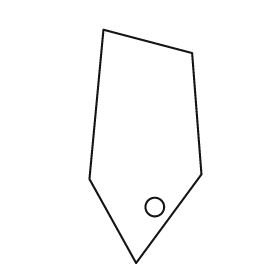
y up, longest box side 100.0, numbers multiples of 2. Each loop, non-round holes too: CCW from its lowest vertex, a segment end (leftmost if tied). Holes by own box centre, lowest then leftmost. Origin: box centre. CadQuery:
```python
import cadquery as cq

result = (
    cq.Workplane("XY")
    .moveTo(-4.0, -50.0)
    .lineTo(24.0, -12.0)
    .lineTo(20.0, 40.0)
    .lineTo(-18.0, 50.0)
    .lineTo(-24.0, -14.0)
    .close()
    .moveTo(4.0, -26.0)
    .circle(4.0)
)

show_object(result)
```